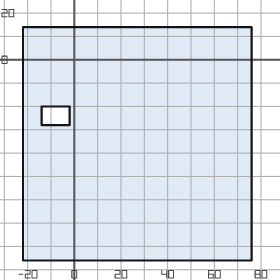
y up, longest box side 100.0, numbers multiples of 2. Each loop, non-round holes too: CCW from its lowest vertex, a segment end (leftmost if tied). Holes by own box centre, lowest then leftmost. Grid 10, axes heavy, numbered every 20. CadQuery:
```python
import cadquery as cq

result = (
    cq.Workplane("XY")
    .moveTo(-22.0, -86.0)
    .lineTo(76.0, -86.0)
    .lineTo(76.0, 14.0)
    .lineTo(-22.0, 14.0)
    .close()
    .moveTo(-14.0, -28.0)
    .lineTo(-2.0, -28.0)
    .lineTo(-2.0, -20.0)
    .lineTo(-14.0, -20.0)
    .close()
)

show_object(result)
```